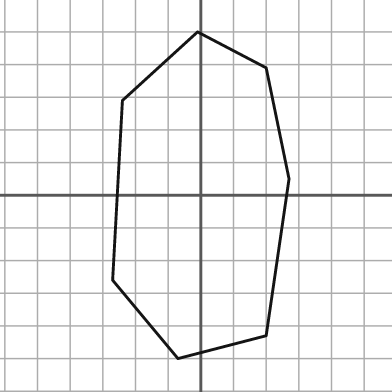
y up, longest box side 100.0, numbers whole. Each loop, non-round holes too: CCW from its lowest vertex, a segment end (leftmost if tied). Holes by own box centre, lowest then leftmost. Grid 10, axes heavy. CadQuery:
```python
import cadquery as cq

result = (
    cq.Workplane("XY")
    .moveTo(-7.0, -50.0)
    .lineTo(20.0, -43.0)
    .lineTo(27.0, 5.0)
    .lineTo(20.0, 39.0)
    .lineTo(-1.0, 50.0)
    .lineTo(-24.0, 29.0)
    .lineTo(-27.0, -26.0)
    .close()
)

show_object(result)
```